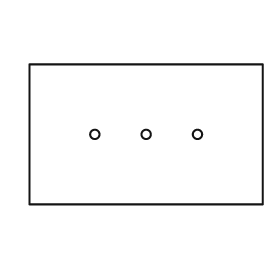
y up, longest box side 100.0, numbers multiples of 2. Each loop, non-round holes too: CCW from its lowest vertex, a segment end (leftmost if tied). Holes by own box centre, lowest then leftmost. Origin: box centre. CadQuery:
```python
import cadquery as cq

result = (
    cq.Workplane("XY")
    .moveTo(-50.0, -30.0)
    .lineTo(50.0, -30.0)
    .lineTo(50.0, 30.0)
    .lineTo(-50.0, 30.0)
    .close()
    .moveTo(-22.0, 0.0)
    .circle(2.0)
    .moveTo(0.0, 0.0)
    .circle(2.0)
    .moveTo(22.0, 0.0)
    .circle(2.0)
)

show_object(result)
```